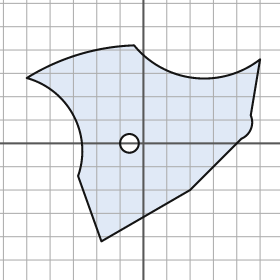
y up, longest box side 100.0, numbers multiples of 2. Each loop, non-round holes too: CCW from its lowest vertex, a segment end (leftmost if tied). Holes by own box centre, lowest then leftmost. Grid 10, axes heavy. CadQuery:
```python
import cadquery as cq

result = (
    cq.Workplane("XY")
    .moveTo(-18.0, -42.0)
    .lineTo(20.0, -20.0)
    .lineTo(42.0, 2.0)
    .threePointArc((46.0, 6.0), (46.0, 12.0))
    .lineTo(50.0, 36.0)
    .threePointArc((22.0, 28.0), (-4.0, 42.0))
    .threePointArc((-28.0, 38.0), (-50.0, 28.0))
    .threePointArc((-30.0, 12.0), (-28.0, -14.0))
    .close()
    .moveTo(-6.0, 0.0)
    .circle(4.0)
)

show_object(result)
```